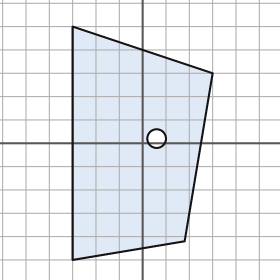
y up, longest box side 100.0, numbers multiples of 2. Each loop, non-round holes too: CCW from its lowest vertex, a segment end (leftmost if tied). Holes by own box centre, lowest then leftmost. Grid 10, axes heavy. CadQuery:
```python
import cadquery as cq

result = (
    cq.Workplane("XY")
    .moveTo(-30.0, -50.0)
    .lineTo(18.0, -42.0)
    .lineTo(30.0, 30.0)
    .lineTo(-30.0, 50.0)
    .close()
    .moveTo(6.0, 2.0)
    .circle(4.0)
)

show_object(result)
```